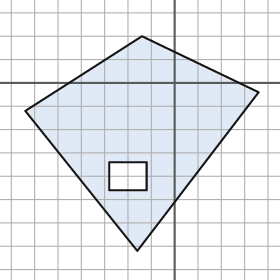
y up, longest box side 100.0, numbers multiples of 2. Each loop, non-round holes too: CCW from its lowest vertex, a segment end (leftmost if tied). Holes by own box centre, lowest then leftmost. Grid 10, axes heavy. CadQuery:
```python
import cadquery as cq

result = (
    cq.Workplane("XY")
    .moveTo(-16.0, -72.0)
    .lineTo(36.0, -4.0)
    .lineTo(-14.0, 20.0)
    .lineTo(-64.0, -12.0)
    .close()
    .moveTo(-28.0, -46.0)
    .lineTo(-12.0, -46.0)
    .lineTo(-12.0, -34.0)
    .lineTo(-28.0, -34.0)
    .close()
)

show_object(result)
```